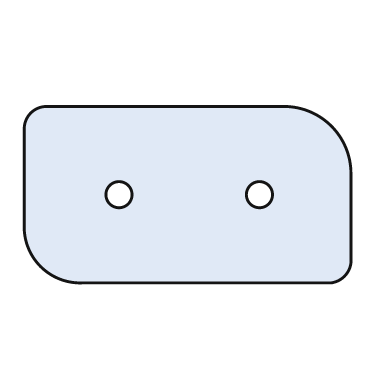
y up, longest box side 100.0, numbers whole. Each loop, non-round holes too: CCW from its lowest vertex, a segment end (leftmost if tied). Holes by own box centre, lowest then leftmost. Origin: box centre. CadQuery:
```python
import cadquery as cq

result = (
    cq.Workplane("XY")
    .moveTo(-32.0, -27.0)
    .lineTo(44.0, -27.0)
    .threePointArc((48.0, -25.0), (50.0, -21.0))
    .lineTo(50.0, 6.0)
    .threePointArc((44.0, 21.0), (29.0, 27.0))
    .lineTo(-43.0, 27.0)
    .threePointArc((-48.0, 25.0), (-50.0, 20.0))
    .lineTo(-50.0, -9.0)
    .threePointArc((-45.0, -22.0), (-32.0, -27.0))
    .close()
    .moveTo(-21.0, 0.0)
    .circle(4.0)
    .moveTo(22.0, 0.0)
    .circle(4.0)
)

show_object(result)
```